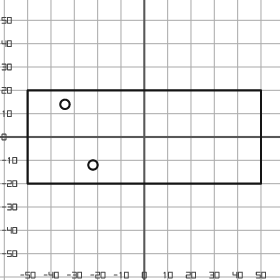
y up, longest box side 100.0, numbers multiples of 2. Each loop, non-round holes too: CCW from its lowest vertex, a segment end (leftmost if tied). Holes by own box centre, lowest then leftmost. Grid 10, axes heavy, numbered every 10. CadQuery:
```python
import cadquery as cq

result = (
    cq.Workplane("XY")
    .moveTo(-50.0, -20.0)
    .lineTo(50.0, -20.0)
    .lineTo(50.0, 20.0)
    .lineTo(-50.0, 20.0)
    .close()
    .moveTo(-22.0, -12.0)
    .circle(2.0)
    .moveTo(-34.0, 14.0)
    .circle(2.0)
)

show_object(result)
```